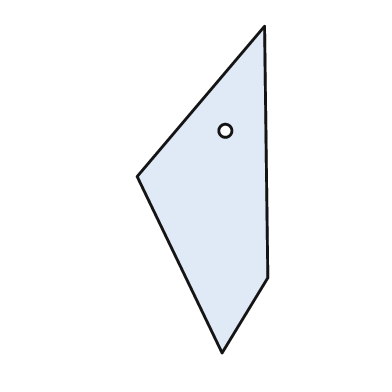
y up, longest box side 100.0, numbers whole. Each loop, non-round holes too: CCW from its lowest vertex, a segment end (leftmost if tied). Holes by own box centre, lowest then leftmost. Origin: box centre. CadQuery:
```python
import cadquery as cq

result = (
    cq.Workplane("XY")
    .moveTo(6.0, -50.0)
    .lineTo(20.0, -27.0)
    .lineTo(19.0, 50.0)
    .lineTo(-20.0, 4.0)
    .close()
    .moveTo(7.0, 18.0)
    .circle(2.0)
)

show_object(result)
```